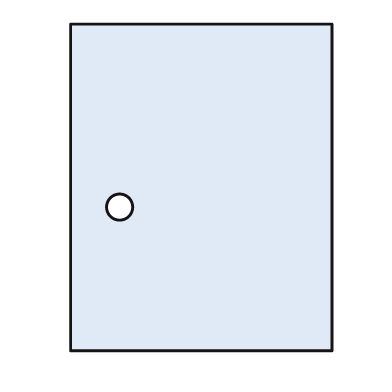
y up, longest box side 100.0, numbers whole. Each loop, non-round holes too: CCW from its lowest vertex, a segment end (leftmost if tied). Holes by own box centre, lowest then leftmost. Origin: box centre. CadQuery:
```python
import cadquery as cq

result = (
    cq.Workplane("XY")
    .moveTo(-40.0, -50.0)
    .lineTo(40.0, -50.0)
    .lineTo(40.0, 50.0)
    .lineTo(-40.0, 50.0)
    .close()
    .moveTo(-25.0, -6.0)
    .circle(4.0)
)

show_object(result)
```